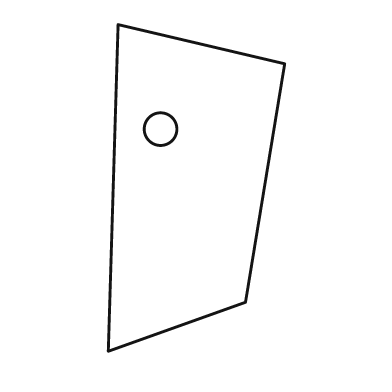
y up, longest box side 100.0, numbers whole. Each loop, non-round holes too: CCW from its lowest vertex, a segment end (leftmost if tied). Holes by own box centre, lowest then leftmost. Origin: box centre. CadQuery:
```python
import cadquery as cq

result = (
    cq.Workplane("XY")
    .moveTo(-27.0, -50.0)
    .lineTo(15.0, -35.0)
    .lineTo(27.0, 38.0)
    .lineTo(-24.0, 50.0)
    .close()
    .moveTo(-11.0, 18.0)
    .circle(5.0)
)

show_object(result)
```